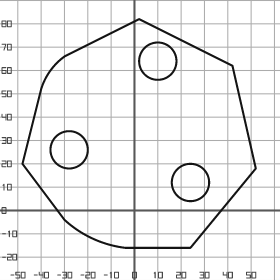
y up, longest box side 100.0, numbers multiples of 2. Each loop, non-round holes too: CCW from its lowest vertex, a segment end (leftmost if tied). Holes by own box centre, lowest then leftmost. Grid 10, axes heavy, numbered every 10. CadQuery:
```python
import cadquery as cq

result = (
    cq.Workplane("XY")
    .moveTo(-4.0, -16.0)
    .lineTo(24.0, -16.0)
    .lineTo(52.0, 18.0)
    .lineTo(42.0, 62.0)
    .lineTo(2.0, 82.0)
    .lineTo(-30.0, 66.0)
    .threePointArc((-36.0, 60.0), (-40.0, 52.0))
    .lineTo(-48.0, 20.0)
    .lineTo(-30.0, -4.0)
    .threePointArc((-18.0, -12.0), (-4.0, -16.0))
    .close()
    .moveTo(24.0, 12.0)
    .circle(8.0)
    .moveTo(-28.0, 26.0)
    .circle(8.0)
    .moveTo(10.0, 64.0)
    .circle(8.0)
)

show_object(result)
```